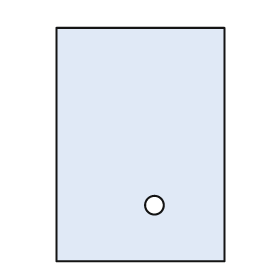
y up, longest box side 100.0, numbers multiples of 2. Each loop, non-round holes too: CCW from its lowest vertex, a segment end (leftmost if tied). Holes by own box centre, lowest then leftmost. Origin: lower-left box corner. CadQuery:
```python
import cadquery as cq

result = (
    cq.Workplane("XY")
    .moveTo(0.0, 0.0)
    .lineTo(72.0, 0.0)
    .lineTo(72.0, 100.0)
    .lineTo(0.0, 100.0)
    .close()
    .moveTo(42.0, 24.0)
    .circle(4.0)
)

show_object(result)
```